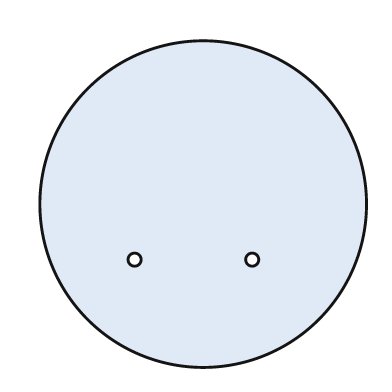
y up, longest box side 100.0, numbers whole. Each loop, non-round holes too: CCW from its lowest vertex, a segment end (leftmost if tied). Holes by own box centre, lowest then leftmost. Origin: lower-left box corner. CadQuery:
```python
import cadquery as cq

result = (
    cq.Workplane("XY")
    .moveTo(50.0, 50.0)
    .circle(50.0)
    .moveTo(29.0, 33.0)
    .circle(2.0)
    .moveTo(65.0, 33.0)
    .circle(2.0)
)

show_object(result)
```